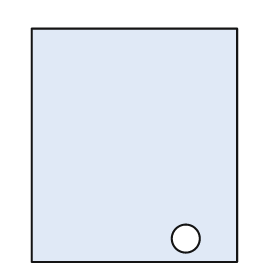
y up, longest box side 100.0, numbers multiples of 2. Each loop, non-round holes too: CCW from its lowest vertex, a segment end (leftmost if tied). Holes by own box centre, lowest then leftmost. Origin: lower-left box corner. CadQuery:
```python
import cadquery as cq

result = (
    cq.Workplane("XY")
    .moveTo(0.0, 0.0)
    .lineTo(88.0, 0.0)
    .lineTo(88.0, 100.0)
    .lineTo(0.0, 100.0)
    .close()
    .moveTo(66.0, 10.0)
    .circle(6.0)
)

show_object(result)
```